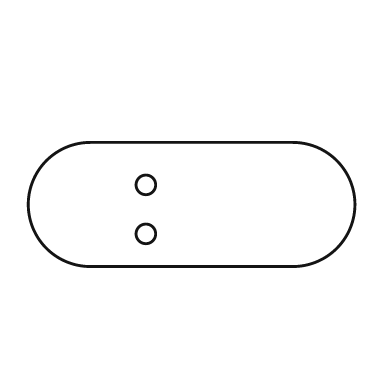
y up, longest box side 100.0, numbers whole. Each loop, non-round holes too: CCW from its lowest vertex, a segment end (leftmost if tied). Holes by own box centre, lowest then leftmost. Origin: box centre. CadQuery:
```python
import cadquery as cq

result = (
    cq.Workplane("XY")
    .moveTo(-31.0, -19.0)
    .lineTo(31.0, -19.0)
    .threePointArc((50.0, 0.0), (31.0, 19.0))
    .lineTo(-31.0, 19.0)
    .threePointArc((-50.0, 0.0), (-31.0, -19.0))
    .close()
    .moveTo(-14.0, -9.0)
    .circle(3.0)
    .moveTo(-14.0, 6.0)
    .circle(3.0)
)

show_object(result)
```